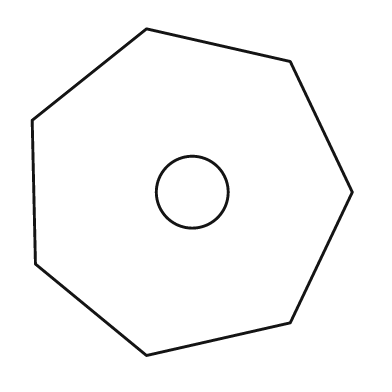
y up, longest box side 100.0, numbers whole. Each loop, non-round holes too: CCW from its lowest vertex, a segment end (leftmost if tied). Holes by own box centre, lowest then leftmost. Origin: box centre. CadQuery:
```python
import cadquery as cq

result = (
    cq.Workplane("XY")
    .moveTo(-14.0, -50.0)
    .lineTo(30.0, -40.0)
    .lineTo(49.0, 0.0)
    .lineTo(30.0, 40.0)
    .lineTo(-14.0, 50.0)
    .lineTo(-49.0, 22.0)
    .lineTo(-48.0, -22.0)
    .close()
    .moveTo(0.0, 0.0)
    .circle(11.0)
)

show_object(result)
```